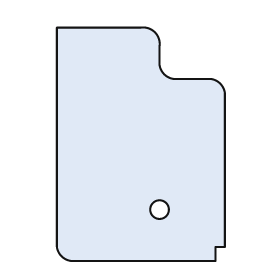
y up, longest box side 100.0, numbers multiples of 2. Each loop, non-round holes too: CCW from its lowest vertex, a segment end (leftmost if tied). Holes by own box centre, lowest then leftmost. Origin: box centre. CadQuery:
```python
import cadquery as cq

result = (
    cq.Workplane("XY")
    .moveTo(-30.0, -50.0)
    .lineTo(32.0, -50.0)
    .lineTo(32.0, -44.0)
    .lineTo(36.0, -44.0)
    .lineTo(36.0, 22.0)
    .threePointArc((34.0, 26.0), (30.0, 28.0))
    .lineTo(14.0, 28.0)
    .threePointArc((10.0, 30.0), (8.0, 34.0))
    .lineTo(8.0, 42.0)
    .threePointArc((6.0, 48.0), (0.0, 50.0))
    .lineTo(-36.0, 50.0)
    .lineTo(-36.0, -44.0)
    .threePointArc((-34.0, -48.0), (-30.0, -50.0))
    .close()
    .moveTo(8.0, -28.0)
    .circle(4.0)
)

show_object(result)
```